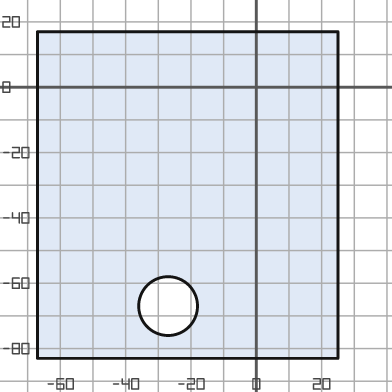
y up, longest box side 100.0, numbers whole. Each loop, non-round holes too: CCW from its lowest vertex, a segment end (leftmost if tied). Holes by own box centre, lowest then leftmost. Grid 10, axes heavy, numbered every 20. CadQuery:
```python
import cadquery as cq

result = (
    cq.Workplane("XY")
    .moveTo(-67.0, -83.0)
    .lineTo(25.0, -83.0)
    .lineTo(25.0, 17.0)
    .lineTo(-67.0, 17.0)
    .close()
    .moveTo(-27.0, -67.0)
    .circle(9.0)
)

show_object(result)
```